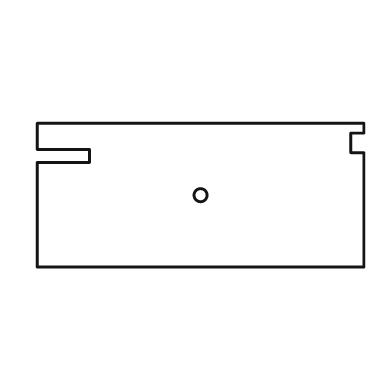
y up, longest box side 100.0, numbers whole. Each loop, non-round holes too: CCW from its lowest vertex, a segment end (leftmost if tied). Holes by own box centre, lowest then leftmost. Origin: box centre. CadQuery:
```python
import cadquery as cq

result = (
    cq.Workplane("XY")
    .moveTo(-50.0, -22.0)
    .lineTo(50.0, -22.0)
    .lineTo(50.0, 13.0)
    .lineTo(46.0, 13.0)
    .lineTo(46.0, 19.0)
    .lineTo(50.0, 19.0)
    .lineTo(50.0, 22.0)
    .lineTo(-50.0, 22.0)
    .lineTo(-50.0, 14.0)
    .lineTo(-34.0, 14.0)
    .lineTo(-34.0, 10.0)
    .lineTo(-50.0, 10.0)
    .close()
    .moveTo(0.0, 0.0)
    .circle(2.0)
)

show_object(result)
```